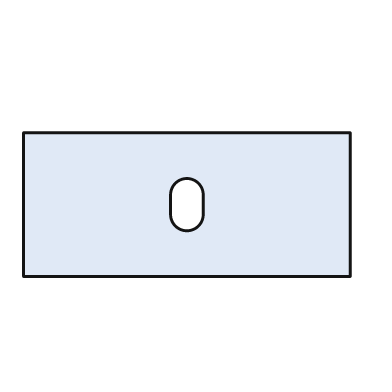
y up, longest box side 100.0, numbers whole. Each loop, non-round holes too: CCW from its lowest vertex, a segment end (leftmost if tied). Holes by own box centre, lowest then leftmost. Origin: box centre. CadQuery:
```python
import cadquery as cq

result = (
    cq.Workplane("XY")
    .moveTo(-50.0, -22.0)
    .lineTo(50.0, -22.0)
    .lineTo(50.0, 22.0)
    .lineTo(-50.0, 22.0)
    .close()
    .moveTo(-5.0, -3.0)
    .threePointArc((0.0, -8.0), (5.0, -3.0))
    .lineTo(5.0, 3.0)
    .threePointArc((0.0, 8.0), (-5.0, 3.0))
    .close()
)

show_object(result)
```